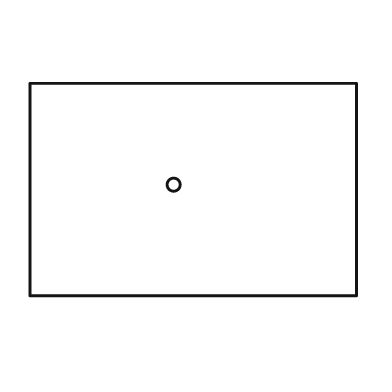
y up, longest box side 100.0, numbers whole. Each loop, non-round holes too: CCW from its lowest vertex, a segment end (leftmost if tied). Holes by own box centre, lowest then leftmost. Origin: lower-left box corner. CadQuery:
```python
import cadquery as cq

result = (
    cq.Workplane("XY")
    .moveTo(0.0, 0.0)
    .lineTo(100.0, 0.0)
    .lineTo(100.0, 65.0)
    .lineTo(0.0, 65.0)
    .close()
    .moveTo(44.0, 34.0)
    .circle(2.0)
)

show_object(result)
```